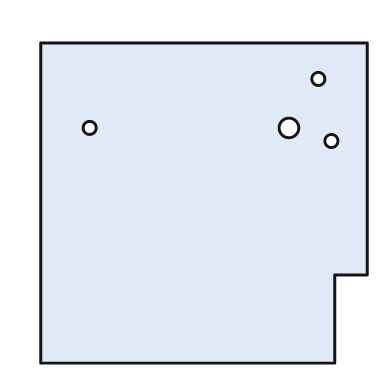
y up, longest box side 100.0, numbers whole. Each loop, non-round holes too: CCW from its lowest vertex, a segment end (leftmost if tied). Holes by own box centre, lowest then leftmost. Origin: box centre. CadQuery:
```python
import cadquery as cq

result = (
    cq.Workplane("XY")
    .moveTo(-50.0, -49.0)
    .lineTo(40.0, -49.0)
    .lineTo(40.0, -22.0)
    .lineTo(50.0, -22.0)
    .lineTo(50.0, 49.0)
    .lineTo(-50.0, 49.0)
    .close()
    .moveTo(39.0, 19.0)
    .circle(2.0)
    .moveTo(-35.0, 23.0)
    .circle(2.0)
    .moveTo(26.0, 23.0)
    .circle(3.0)
    .moveTo(35.0, 38.0)
    .circle(2.0)
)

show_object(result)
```